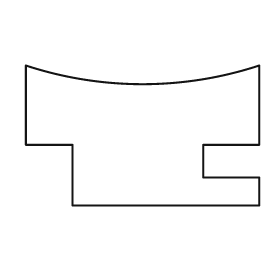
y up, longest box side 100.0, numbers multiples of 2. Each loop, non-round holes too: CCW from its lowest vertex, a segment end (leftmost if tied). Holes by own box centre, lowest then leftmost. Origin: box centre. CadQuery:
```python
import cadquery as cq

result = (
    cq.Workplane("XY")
    .moveTo(-30.0, -30.0)
    .lineTo(50.0, -30.0)
    .lineTo(50.0, -18.0)
    .lineTo(26.0, -18.0)
    .lineTo(26.0, -4.0)
    .lineTo(50.0, -4.0)
    .lineTo(50.0, 30.0)
    .threePointArc((0.0, 22.0), (-50.0, 30.0))
    .lineTo(-50.0, -4.0)
    .lineTo(-30.0, -4.0)
    .close()
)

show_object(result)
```